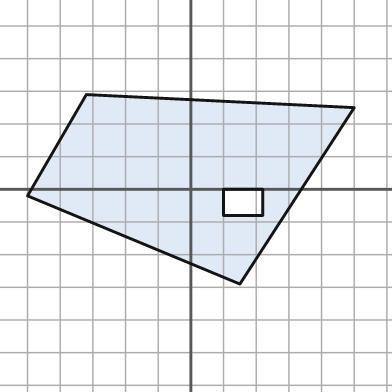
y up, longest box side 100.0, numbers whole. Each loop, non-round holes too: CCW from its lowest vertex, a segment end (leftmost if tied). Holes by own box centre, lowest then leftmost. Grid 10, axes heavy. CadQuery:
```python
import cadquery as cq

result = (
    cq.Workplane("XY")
    .moveTo(15.0, -29.0)
    .lineTo(50.0, 25.0)
    .lineTo(-32.0, 29.0)
    .lineTo(-50.0, -2.0)
    .close()
    .moveTo(10.0, -8.0)
    .lineTo(22.0, -8.0)
    .lineTo(22.0, 0.0)
    .lineTo(10.0, 0.0)
    .close()
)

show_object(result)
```